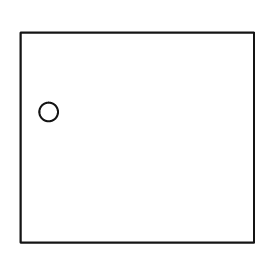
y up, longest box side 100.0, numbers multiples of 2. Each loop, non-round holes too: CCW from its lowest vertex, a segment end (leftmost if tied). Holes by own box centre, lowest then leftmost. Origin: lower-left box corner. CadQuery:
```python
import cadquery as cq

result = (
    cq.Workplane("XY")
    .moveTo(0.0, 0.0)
    .lineTo(100.0, 0.0)
    .lineTo(100.0, 90.0)
    .lineTo(0.0, 90.0)
    .close()
    .moveTo(12.0, 56.0)
    .circle(4.0)
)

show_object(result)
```